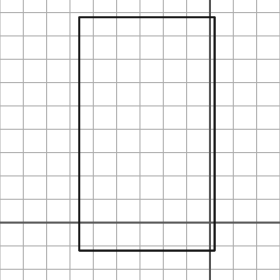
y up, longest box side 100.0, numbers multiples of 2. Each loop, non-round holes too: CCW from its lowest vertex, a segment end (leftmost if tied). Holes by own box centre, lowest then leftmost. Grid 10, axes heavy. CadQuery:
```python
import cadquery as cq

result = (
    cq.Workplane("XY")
    .moveTo(-56.0, -12.0)
    .lineTo(2.0, -12.0)
    .lineTo(2.0, 88.0)
    .lineTo(-56.0, 88.0)
    .close()
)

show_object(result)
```